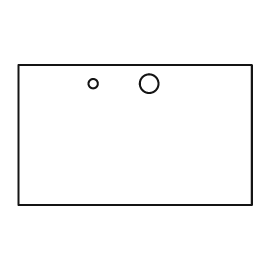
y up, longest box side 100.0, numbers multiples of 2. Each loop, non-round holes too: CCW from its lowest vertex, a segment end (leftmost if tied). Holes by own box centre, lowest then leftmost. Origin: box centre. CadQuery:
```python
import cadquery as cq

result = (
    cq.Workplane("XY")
    .moveTo(-50.0, -30.0)
    .lineTo(50.0, -30.0)
    .lineTo(50.0, 30.0)
    .lineTo(-50.0, 30.0)
    .close()
    .moveTo(-18.0, 22.0)
    .circle(2.0)
    .moveTo(6.0, 22.0)
    .circle(4.0)
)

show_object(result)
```